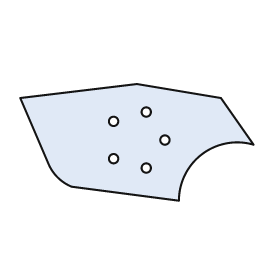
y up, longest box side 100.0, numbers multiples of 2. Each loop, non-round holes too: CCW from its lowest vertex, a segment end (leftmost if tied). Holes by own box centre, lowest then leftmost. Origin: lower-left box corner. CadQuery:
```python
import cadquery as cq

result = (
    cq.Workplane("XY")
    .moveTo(68.0, 0.0)
    .threePointArc((78.0, 20.0), (100.0, 24.0))
    .lineTo(86.0, 44.0)
    .lineTo(50.0, 50.0)
    .lineTo(0.0, 44.0)
    .lineTo(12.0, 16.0)
    .threePointArc((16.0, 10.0), (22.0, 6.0))
    .close()
    .moveTo(54.0, 14.0)
    .circle(2.0)
    .moveTo(40.0, 18.0)
    .circle(2.0)
    .moveTo(62.0, 26.0)
    .circle(2.0)
    .moveTo(40.0, 34.0)
    .circle(2.0)
    .moveTo(54.0, 38.0)
    .circle(2.0)
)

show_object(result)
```